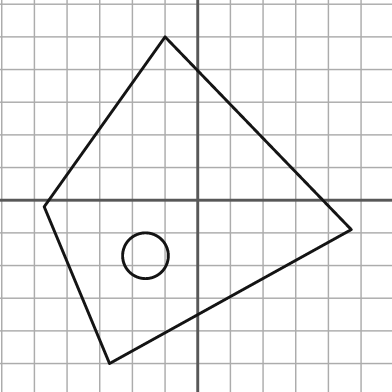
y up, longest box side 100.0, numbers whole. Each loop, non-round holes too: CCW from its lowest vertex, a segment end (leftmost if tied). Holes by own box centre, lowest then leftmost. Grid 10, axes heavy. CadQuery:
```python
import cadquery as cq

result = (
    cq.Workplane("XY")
    .moveTo(-27.0, -50.0)
    .lineTo(47.0, -9.0)
    .lineTo(-10.0, 50.0)
    .lineTo(-47.0, -2.0)
    .close()
    .moveTo(-16.0, -17.0)
    .circle(7.0)
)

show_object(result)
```